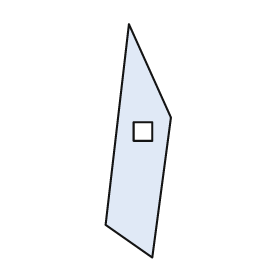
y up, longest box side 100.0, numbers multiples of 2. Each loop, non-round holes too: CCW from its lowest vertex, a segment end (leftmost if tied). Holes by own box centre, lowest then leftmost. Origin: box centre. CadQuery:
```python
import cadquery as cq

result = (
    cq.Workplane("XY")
    .moveTo(6.0, -50.0)
    .lineTo(14.0, 10.0)
    .lineTo(-4.0, 50.0)
    .lineTo(-14.0, -36.0)
    .close()
    .moveTo(-2.0, 0.0)
    .lineTo(6.0, 0.0)
    .lineTo(6.0, 8.0)
    .lineTo(-2.0, 8.0)
    .close()
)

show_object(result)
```